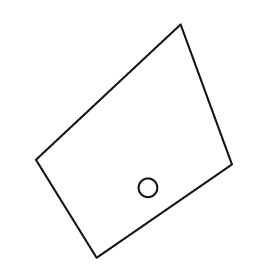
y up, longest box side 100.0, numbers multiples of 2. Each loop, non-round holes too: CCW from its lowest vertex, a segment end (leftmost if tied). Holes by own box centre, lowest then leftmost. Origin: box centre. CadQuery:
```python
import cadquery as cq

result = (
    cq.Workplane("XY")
    .moveTo(-16.0, -50.0)
    .lineTo(42.0, -10.0)
    .lineTo(20.0, 50.0)
    .lineTo(-42.0, -8.0)
    .close()
    .moveTo(6.0, -20.0)
    .circle(4.0)
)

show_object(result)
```